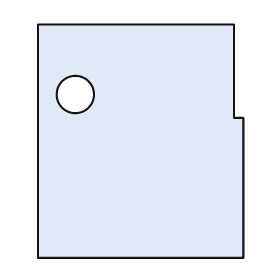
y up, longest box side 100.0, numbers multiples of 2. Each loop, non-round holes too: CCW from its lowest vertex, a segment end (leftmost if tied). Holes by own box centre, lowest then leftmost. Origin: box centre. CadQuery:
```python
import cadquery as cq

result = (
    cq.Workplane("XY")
    .moveTo(-44.0, -50.0)
    .lineTo(44.0, -50.0)
    .lineTo(44.0, 10.0)
    .lineTo(40.0, 10.0)
    .lineTo(40.0, 50.0)
    .lineTo(-44.0, 50.0)
    .close()
    .moveTo(-28.0, 20.0)
    .circle(8.0)
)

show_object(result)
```